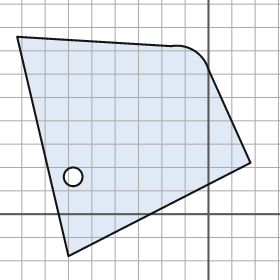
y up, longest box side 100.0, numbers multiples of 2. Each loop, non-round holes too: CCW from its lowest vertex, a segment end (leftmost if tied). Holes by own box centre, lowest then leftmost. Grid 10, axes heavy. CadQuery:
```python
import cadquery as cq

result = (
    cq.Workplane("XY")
    .moveTo(-60.0, -18.0)
    .lineTo(18.0, 22.0)
    .lineTo(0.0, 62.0)
    .threePointArc((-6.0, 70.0), (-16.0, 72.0))
    .lineTo(-82.0, 76.0)
    .close()
    .moveTo(-58.0, 16.0)
    .circle(4.0)
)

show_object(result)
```